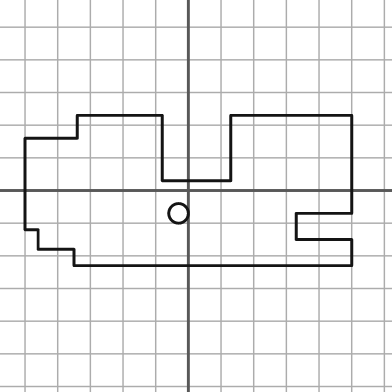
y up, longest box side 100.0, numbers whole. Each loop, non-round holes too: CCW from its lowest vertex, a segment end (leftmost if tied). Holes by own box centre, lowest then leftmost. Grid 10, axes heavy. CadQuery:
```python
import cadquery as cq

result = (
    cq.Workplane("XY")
    .moveTo(-35.0, -23.0)
    .lineTo(50.0, -23.0)
    .lineTo(50.0, -15.0)
    .lineTo(33.0, -15.0)
    .lineTo(33.0, -7.0)
    .lineTo(50.0, -7.0)
    .lineTo(50.0, 23.0)
    .lineTo(13.0, 23.0)
    .lineTo(13.0, 3.0)
    .lineTo(-8.0, 3.0)
    .lineTo(-8.0, 23.0)
    .lineTo(-34.0, 23.0)
    .lineTo(-34.0, 16.0)
    .lineTo(-50.0, 16.0)
    .lineTo(-50.0, -12.0)
    .lineTo(-46.0, -12.0)
    .lineTo(-46.0, -18.0)
    .lineTo(-35.0, -18.0)
    .close()
    .moveTo(-3.0, -7.0)
    .circle(3.0)
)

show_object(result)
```